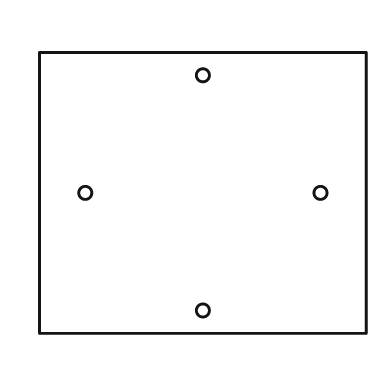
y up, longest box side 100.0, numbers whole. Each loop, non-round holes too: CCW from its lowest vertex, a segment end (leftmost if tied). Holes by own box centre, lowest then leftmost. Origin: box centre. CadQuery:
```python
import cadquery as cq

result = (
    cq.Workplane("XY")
    .moveTo(-50.0, -43.0)
    .lineTo(50.0, -43.0)
    .lineTo(50.0, 43.0)
    .lineTo(-50.0, 43.0)
    .close()
    .moveTo(0.0, -36.0)
    .circle(2.0)
    .moveTo(-36.0, 0.0)
    .circle(2.0)
    .moveTo(36.0, 0.0)
    .circle(2.0)
    .moveTo(0.0, 36.0)
    .circle(2.0)
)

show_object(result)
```